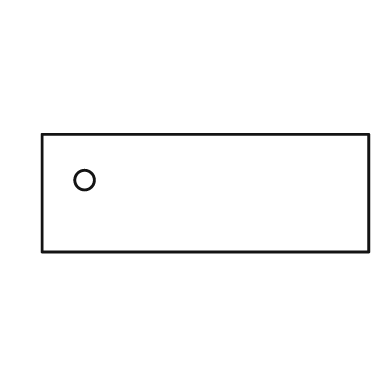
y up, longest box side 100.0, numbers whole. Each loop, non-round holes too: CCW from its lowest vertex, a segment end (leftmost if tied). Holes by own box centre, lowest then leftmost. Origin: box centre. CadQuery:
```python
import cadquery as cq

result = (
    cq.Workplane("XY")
    .moveTo(-50.0, -18.0)
    .lineTo(50.0, -18.0)
    .lineTo(50.0, 18.0)
    .lineTo(-50.0, 18.0)
    .close()
    .moveTo(-37.0, 4.0)
    .circle(3.0)
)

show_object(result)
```